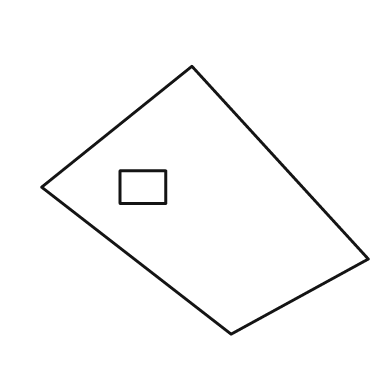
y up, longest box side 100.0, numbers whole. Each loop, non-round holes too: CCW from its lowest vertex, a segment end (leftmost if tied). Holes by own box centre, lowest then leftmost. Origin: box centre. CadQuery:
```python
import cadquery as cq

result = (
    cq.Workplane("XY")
    .moveTo(8.0, -41.0)
    .lineTo(50.0, -18.0)
    .lineTo(-4.0, 41.0)
    .lineTo(-50.0, 4.0)
    .close()
    .moveTo(-26.0, -1.0)
    .lineTo(-12.0, -1.0)
    .lineTo(-12.0, 9.0)
    .lineTo(-26.0, 9.0)
    .close()
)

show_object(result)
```